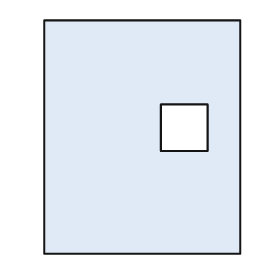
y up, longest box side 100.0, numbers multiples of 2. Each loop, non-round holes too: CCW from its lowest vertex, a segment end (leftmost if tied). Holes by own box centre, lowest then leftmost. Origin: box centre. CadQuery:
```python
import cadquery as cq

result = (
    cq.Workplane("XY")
    .moveTo(-42.0, -50.0)
    .lineTo(42.0, -50.0)
    .lineTo(42.0, 50.0)
    .lineTo(-42.0, 50.0)
    .close()
    .moveTo(8.0, -6.0)
    .lineTo(28.0, -6.0)
    .lineTo(28.0, 14.0)
    .lineTo(8.0, 14.0)
    .close()
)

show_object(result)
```